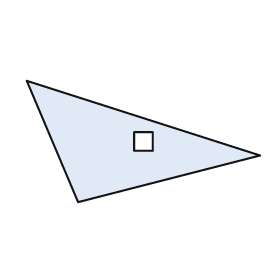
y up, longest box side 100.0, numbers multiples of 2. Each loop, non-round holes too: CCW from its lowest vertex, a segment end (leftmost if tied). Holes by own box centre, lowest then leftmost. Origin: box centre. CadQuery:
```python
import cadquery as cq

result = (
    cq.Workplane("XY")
    .moveTo(-28.0, -26.0)
    .lineTo(50.0, -6.0)
    .lineTo(-50.0, 26.0)
    .close()
    .moveTo(-4.0, -4.0)
    .lineTo(4.0, -4.0)
    .lineTo(4.0, 4.0)
    .lineTo(-4.0, 4.0)
    .close()
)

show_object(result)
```